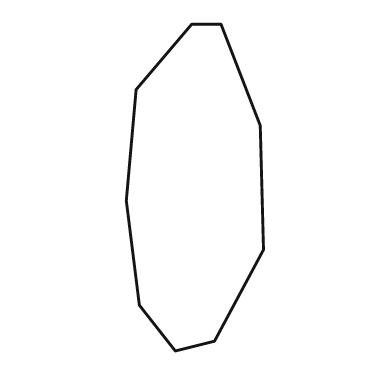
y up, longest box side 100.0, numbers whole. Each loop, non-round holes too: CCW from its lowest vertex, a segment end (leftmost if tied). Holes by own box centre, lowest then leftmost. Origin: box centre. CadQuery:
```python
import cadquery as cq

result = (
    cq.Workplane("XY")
    .moveTo(-6.0, -50.0)
    .lineTo(6.0, -47.0)
    .lineTo(21.0, -19.0)
    .lineTo(20.0, 19.0)
    .lineTo(8.0, 50.0)
    .lineTo(-1.0, 50.0)
    .lineTo(-18.0, 30.0)
    .lineTo(-21.0, -4.0)
    .lineTo(-17.0, -36.0)
    .close()
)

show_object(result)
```